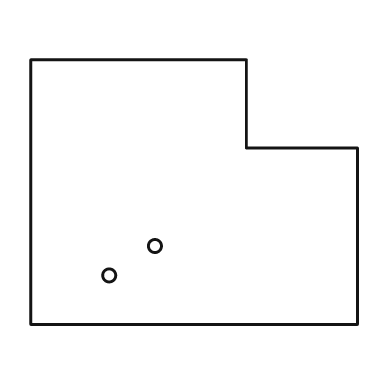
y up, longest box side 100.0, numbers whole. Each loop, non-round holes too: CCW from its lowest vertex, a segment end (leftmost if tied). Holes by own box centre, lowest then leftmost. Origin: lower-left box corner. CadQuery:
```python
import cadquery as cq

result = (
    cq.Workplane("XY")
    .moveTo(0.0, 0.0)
    .lineTo(100.0, 0.0)
    .lineTo(100.0, 54.0)
    .lineTo(66.0, 54.0)
    .lineTo(66.0, 81.0)
    .lineTo(0.0, 81.0)
    .close()
    .moveTo(24.0, 15.0)
    .circle(2.0)
    .moveTo(38.0, 24.0)
    .circle(2.0)
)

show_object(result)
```